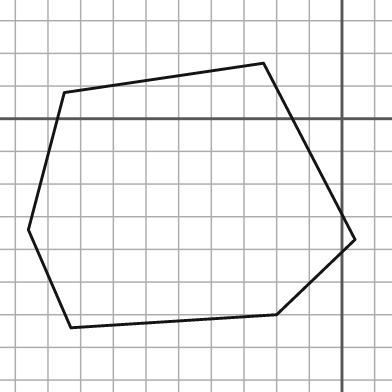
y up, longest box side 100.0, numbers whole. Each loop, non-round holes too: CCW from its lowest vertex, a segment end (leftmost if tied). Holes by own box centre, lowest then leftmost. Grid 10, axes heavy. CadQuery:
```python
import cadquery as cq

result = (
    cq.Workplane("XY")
    .moveTo(-83.0, -64.0)
    .lineTo(-20.0, -60.0)
    .lineTo(4.0, -37.0)
    .lineTo(-24.0, 17.0)
    .lineTo(-85.0, 8.0)
    .lineTo(-96.0, -34.0)
    .close()
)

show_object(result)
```